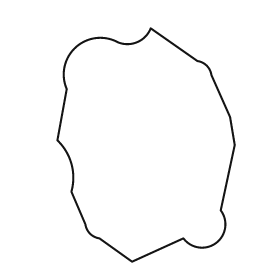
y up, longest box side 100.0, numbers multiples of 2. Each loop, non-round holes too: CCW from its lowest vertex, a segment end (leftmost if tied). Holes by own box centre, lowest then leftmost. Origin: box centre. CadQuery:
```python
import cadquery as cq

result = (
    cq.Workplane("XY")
    .moveTo(-6.0, -50.0)
    .lineTo(16.0, -40.0)
    .threePointArc((30.0, -42.0), (32.0, -28.0))
    .lineTo(38.0, 0.0)
    .lineTo(36.0, 12.0)
    .lineTo(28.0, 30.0)
    .threePointArc((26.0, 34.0), (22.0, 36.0))
    .lineTo(2.0, 50.0)
    .threePointArc((-4.0, 44.0), (-12.0, 44.0))
    .threePointArc((-30.0, 42.0), (-34.0, 24.0))
    .lineTo(-38.0, 2.0)
    .threePointArc((-32.0, -8.0), (-32.0, -20.0))
    .lineTo(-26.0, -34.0)
    .threePointArc((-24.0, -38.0), (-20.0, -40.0))
    .close()
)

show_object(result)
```